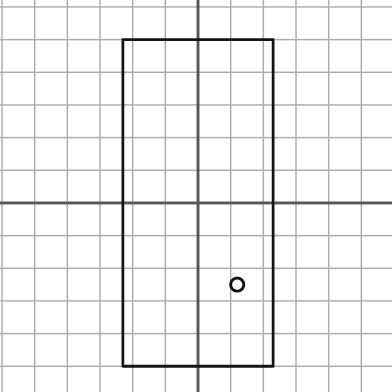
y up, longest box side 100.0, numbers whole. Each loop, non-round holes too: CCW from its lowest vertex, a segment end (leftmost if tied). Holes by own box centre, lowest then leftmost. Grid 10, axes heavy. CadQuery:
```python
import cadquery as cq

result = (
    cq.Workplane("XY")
    .moveTo(-23.0, -50.0)
    .lineTo(23.0, -50.0)
    .lineTo(23.0, 50.0)
    .lineTo(-23.0, 50.0)
    .close()
    .moveTo(12.0, -25.0)
    .circle(2.0)
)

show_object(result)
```